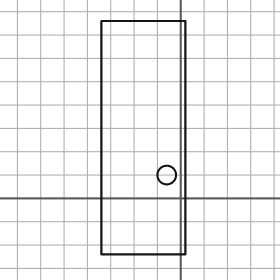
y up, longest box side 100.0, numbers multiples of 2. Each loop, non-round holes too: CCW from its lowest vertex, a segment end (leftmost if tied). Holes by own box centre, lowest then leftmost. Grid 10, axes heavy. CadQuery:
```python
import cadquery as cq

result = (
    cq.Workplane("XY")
    .moveTo(-34.0, -24.0)
    .lineTo(2.0, -24.0)
    .lineTo(2.0, 76.0)
    .lineTo(-34.0, 76.0)
    .close()
    .moveTo(-6.0, 10.0)
    .circle(4.0)
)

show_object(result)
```